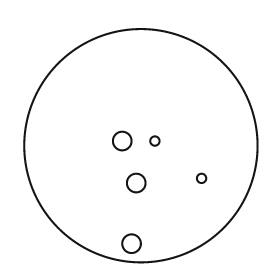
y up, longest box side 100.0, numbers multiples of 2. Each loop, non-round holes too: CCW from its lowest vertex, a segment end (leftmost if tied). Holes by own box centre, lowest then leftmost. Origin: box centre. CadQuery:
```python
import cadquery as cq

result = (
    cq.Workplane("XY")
    .moveTo(0.0, 0.0)
    .circle(50.0)
    .moveTo(-4.0, -42.0)
    .circle(4.0)
    .moveTo(-2.0, -16.0)
    .circle(4.0)
    .moveTo(26.0, -14.0)
    .circle(2.0)
    .moveTo(-8.0, 2.0)
    .circle(4.0)
    .moveTo(6.0, 2.0)
    .circle(2.0)
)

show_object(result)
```